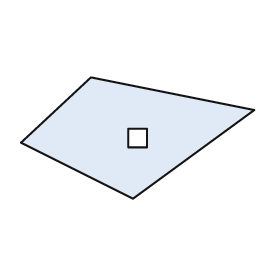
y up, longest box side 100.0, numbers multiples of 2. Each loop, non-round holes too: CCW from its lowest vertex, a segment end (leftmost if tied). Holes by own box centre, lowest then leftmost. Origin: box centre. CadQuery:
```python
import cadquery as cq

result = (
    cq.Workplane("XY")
    .moveTo(-2.0, -26.0)
    .lineTo(50.0, 12.0)
    .lineTo(-20.0, 26.0)
    .lineTo(-50.0, -2.0)
    .close()
    .moveTo(-4.0, -4.0)
    .lineTo(4.0, -4.0)
    .lineTo(4.0, 4.0)
    .lineTo(-4.0, 4.0)
    .close()
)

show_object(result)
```